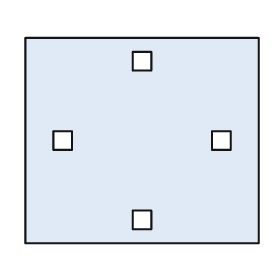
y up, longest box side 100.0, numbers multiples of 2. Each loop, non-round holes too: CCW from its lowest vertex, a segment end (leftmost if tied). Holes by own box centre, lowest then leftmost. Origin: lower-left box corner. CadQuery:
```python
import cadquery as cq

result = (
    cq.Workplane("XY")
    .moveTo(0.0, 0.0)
    .lineTo(100.0, 0.0)
    .lineTo(100.0, 88.0)
    .lineTo(0.0, 88.0)
    .close()
    .moveTo(46.0, 6.0)
    .lineTo(54.0, 6.0)
    .lineTo(54.0, 14.0)
    .lineTo(46.0, 14.0)
    .close()
    .moveTo(12.0, 40.0)
    .lineTo(20.0, 40.0)
    .lineTo(20.0, 48.0)
    .lineTo(12.0, 48.0)
    .close()
    .moveTo(80.0, 40.0)
    .lineTo(88.0, 40.0)
    .lineTo(88.0, 48.0)
    .lineTo(80.0, 48.0)
    .close()
    .moveTo(46.0, 74.0)
    .lineTo(54.0, 74.0)
    .lineTo(54.0, 82.0)
    .lineTo(46.0, 82.0)
    .close()
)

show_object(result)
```